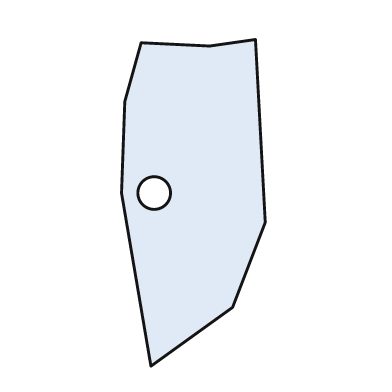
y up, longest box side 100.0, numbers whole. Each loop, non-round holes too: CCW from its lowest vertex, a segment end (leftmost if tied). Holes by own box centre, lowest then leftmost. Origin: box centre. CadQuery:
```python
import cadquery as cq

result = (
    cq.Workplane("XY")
    .moveTo(-13.0, -50.0)
    .lineTo(12.0, -32.0)
    .lineTo(22.0, -6.0)
    .lineTo(19.0, 50.0)
    .lineTo(5.0, 48.0)
    .lineTo(-16.0, 49.0)
    .lineTo(-21.0, 31.0)
    .lineTo(-22.0, 3.0)
    .close()
    .moveTo(-12.0, 3.0)
    .circle(5.0)
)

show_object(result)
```